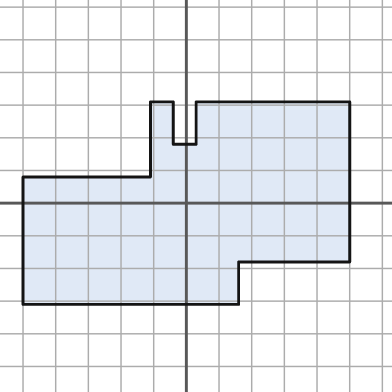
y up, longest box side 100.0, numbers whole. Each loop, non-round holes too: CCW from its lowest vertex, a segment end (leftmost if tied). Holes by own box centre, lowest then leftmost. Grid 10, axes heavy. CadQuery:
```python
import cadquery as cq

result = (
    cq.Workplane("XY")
    .moveTo(-50.0, -31.0)
    .lineTo(16.0, -31.0)
    .lineTo(16.0, -18.0)
    .lineTo(50.0, -18.0)
    .lineTo(50.0, 31.0)
    .lineTo(3.0, 31.0)
    .lineTo(3.0, 18.0)
    .lineTo(-4.0, 18.0)
    .lineTo(-4.0, 31.0)
    .lineTo(-11.0, 31.0)
    .lineTo(-11.0, 8.0)
    .lineTo(-50.0, 8.0)
    .close()
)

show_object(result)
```